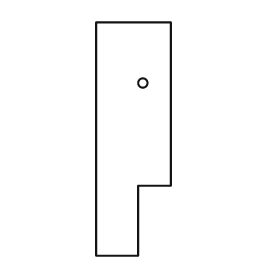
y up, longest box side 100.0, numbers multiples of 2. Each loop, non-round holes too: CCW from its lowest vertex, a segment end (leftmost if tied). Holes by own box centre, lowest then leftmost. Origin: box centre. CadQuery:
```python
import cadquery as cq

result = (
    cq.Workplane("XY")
    .moveTo(-16.0, -50.0)
    .lineTo(2.0, -50.0)
    .lineTo(2.0, -20.0)
    .lineTo(16.0, -20.0)
    .lineTo(16.0, 50.0)
    .lineTo(-16.0, 50.0)
    .close()
    .moveTo(4.0, 24.0)
    .circle(2.0)
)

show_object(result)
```